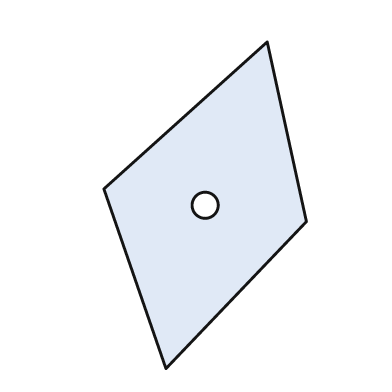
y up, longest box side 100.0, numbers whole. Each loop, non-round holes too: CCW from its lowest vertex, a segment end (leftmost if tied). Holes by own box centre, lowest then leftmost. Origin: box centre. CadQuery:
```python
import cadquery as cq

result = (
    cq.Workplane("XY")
    .moveTo(-12.0, -50.0)
    .lineTo(31.0, -5.0)
    .lineTo(19.0, 50.0)
    .lineTo(-31.0, 5.0)
    .close()
    .moveTo(0.0, 0.0)
    .circle(4.0)
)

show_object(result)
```